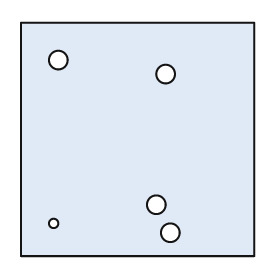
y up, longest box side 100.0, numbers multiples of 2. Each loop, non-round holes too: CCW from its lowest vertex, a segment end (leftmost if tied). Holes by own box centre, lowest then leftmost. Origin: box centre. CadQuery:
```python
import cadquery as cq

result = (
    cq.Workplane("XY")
    .moveTo(-50.0, -50.0)
    .lineTo(50.0, -50.0)
    .lineTo(50.0, 50.0)
    .lineTo(-50.0, 50.0)
    .close()
    .moveTo(14.0, -40.0)
    .circle(4.0)
    .moveTo(-36.0, -36.0)
    .circle(2.0)
    .moveTo(8.0, -28.0)
    .circle(4.0)
    .moveTo(12.0, 28.0)
    .circle(4.0)
    .moveTo(-34.0, 34.0)
    .circle(4.0)
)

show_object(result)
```